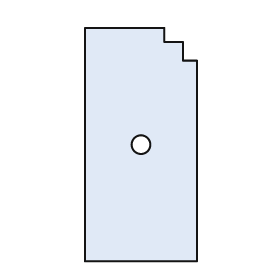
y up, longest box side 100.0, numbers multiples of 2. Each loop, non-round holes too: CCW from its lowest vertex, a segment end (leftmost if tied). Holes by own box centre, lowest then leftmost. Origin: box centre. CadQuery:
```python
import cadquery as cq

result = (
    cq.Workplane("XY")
    .moveTo(-24.0, -50.0)
    .lineTo(24.0, -50.0)
    .lineTo(24.0, 36.0)
    .lineTo(18.0, 36.0)
    .lineTo(18.0, 44.0)
    .lineTo(10.0, 44.0)
    .lineTo(10.0, 50.0)
    .lineTo(-24.0, 50.0)
    .close()
    .moveTo(0.0, 0.0)
    .circle(4.0)
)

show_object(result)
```